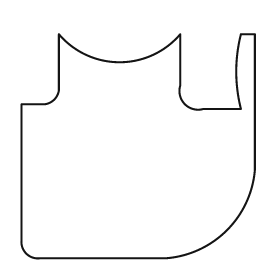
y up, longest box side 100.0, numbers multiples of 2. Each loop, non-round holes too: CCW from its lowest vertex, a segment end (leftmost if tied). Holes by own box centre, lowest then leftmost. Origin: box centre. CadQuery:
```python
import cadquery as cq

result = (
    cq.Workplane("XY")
    .moveTo(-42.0, -48.0)
    .lineTo(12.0, -48.0)
    .threePointArc((38.0, -36.0), (50.0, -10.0))
    .lineTo(50.0, 48.0)
    .lineTo(44.0, 48.0)
    .threePointArc((42.0, 32.0), (44.0, 16.0))
    .lineTo(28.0, 16.0)
    .threePointArc((20.0, 18.0), (18.0, 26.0))
    .lineTo(18.0, 48.0)
    .threePointArc((-8.0, 36.0), (-34.0, 48.0))
    .lineTo(-34.0, 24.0)
    .threePointArc((-36.0, 20.0), (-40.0, 18.0))
    .lineTo(-50.0, 18.0)
    .lineTo(-50.0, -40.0)
    .threePointArc((-48.0, -46.0), (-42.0, -48.0))
    .close()
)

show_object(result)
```